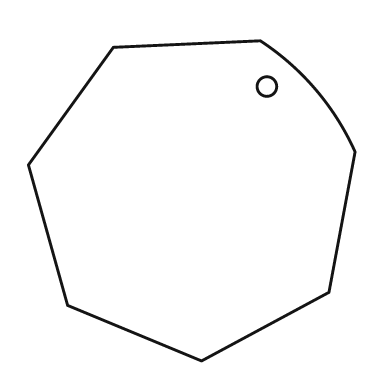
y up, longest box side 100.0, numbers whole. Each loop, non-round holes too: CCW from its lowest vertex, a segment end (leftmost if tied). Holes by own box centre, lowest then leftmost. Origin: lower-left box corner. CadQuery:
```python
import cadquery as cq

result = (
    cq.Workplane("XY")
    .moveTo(53.0, 0.0)
    .lineTo(92.0, 21.0)
    .lineTo(100.0, 64.0)
    .threePointArc((88.0, 83.0), (71.0, 98.0))
    .lineTo(26.0, 96.0)
    .lineTo(0.0, 60.0)
    .lineTo(12.0, 17.0)
    .close()
    .moveTo(73.0, 84.0)
    .circle(3.0)
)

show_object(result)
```